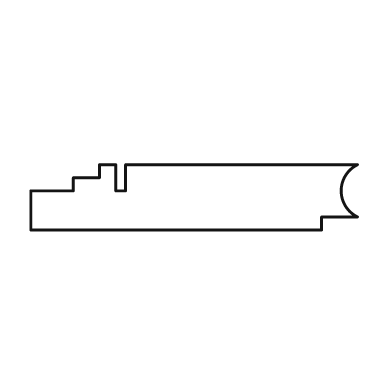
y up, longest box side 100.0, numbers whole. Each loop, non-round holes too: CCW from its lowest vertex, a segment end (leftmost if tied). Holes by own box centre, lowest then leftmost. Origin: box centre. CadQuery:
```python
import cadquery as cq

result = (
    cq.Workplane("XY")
    .moveTo(-50.0, -10.0)
    .lineTo(39.0, -10.0)
    .lineTo(39.0, -6.0)
    .lineTo(50.0, -6.0)
    .threePointArc((45.0, 2.0), (50.0, 10.0))
    .lineTo(-21.0, 10.0)
    .lineTo(-21.0, 2.0)
    .lineTo(-24.0, 2.0)
    .lineTo(-24.0, 10.0)
    .lineTo(-29.0, 10.0)
    .lineTo(-29.0, 6.0)
    .lineTo(-37.0, 6.0)
    .lineTo(-37.0, 2.0)
    .lineTo(-50.0, 2.0)
    .close()
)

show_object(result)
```